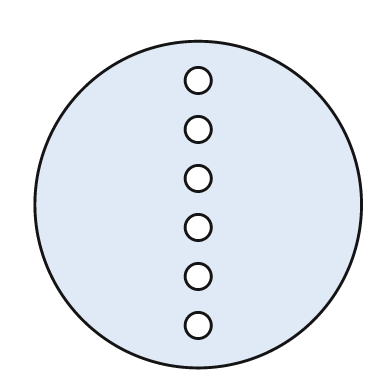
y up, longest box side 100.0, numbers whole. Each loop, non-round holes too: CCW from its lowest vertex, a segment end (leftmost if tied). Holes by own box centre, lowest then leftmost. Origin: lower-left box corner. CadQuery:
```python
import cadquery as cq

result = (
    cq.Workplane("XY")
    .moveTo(50.0, 50.0)
    .circle(50.0)
    .moveTo(50.0, 13.0)
    .circle(4.0)
    .moveTo(50.0, 28.0)
    .circle(4.0)
    .moveTo(50.0, 43.0)
    .circle(4.0)
    .moveTo(50.0, 58.0)
    .circle(4.0)
    .moveTo(50.0, 73.0)
    .circle(4.0)
    .moveTo(50.0, 88.0)
    .circle(4.0)
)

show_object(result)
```